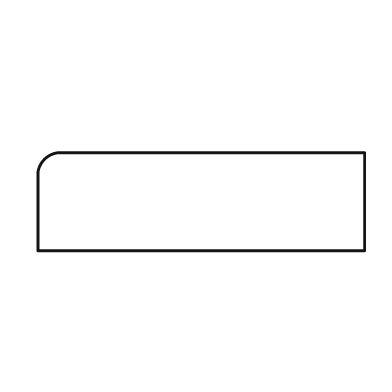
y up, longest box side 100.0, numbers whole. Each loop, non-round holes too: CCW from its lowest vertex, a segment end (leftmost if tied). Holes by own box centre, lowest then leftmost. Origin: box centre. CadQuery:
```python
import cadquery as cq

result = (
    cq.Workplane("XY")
    .moveTo(-50.0, -15.0)
    .lineTo(50.0, -15.0)
    .lineTo(50.0, 15.0)
    .lineTo(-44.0, 15.0)
    .threePointArc((-48.0, 13.0), (-50.0, 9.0))
    .close()
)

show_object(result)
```